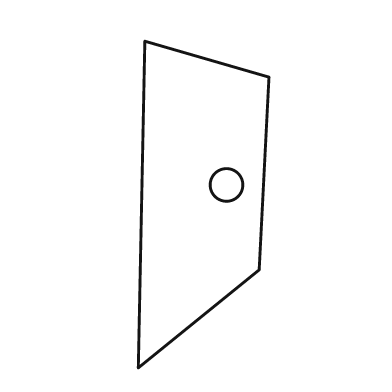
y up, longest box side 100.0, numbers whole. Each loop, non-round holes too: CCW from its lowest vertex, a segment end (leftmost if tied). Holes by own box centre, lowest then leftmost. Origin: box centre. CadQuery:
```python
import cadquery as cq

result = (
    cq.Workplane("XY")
    .moveTo(-20.0, -50.0)
    .lineTo(17.0, -20.0)
    .lineTo(20.0, 39.0)
    .lineTo(-18.0, 50.0)
    .close()
    .moveTo(7.0, 6.0)
    .circle(5.0)
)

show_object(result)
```